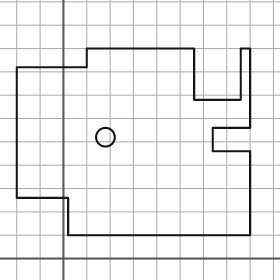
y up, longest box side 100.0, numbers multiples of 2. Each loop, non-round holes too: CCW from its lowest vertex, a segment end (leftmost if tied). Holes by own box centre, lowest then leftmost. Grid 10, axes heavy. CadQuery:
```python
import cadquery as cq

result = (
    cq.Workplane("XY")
    .moveTo(2.0, 10.0)
    .lineTo(80.0, 10.0)
    .lineTo(80.0, 46.0)
    .lineTo(64.0, 46.0)
    .lineTo(64.0, 56.0)
    .lineTo(80.0, 56.0)
    .lineTo(80.0, 90.0)
    .lineTo(76.0, 90.0)
    .lineTo(76.0, 68.0)
    .lineTo(56.0, 68.0)
    .lineTo(56.0, 90.0)
    .lineTo(10.0, 90.0)
    .lineTo(10.0, 82.0)
    .lineTo(-20.0, 82.0)
    .lineTo(-20.0, 26.0)
    .lineTo(2.0, 26.0)
    .close()
    .moveTo(18.0, 52.0)
    .circle(4.0)
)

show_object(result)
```